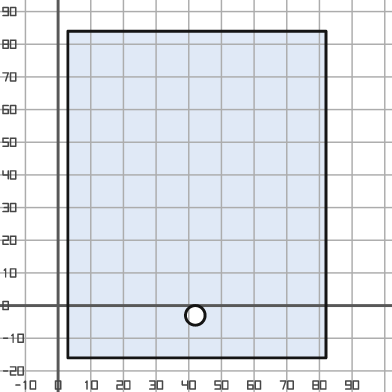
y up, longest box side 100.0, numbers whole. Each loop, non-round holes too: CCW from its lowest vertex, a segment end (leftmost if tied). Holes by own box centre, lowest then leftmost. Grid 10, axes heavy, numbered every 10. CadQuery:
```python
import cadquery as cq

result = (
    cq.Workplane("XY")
    .moveTo(3.0, -16.0)
    .lineTo(82.0, -16.0)
    .lineTo(82.0, 84.0)
    .lineTo(3.0, 84.0)
    .close()
    .moveTo(42.0, -3.0)
    .circle(3.0)
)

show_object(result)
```